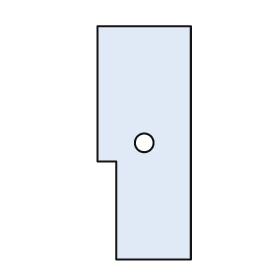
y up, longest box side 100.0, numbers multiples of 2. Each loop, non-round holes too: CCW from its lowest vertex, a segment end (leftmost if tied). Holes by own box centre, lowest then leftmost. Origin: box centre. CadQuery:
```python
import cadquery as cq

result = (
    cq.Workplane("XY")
    .moveTo(-12.0, -50.0)
    .lineTo(20.0, -50.0)
    .lineTo(20.0, 50.0)
    .lineTo(-20.0, 50.0)
    .lineTo(-20.0, -8.0)
    .lineTo(-12.0, -8.0)
    .close()
    .moveTo(0.0, 0.0)
    .circle(4.0)
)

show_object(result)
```